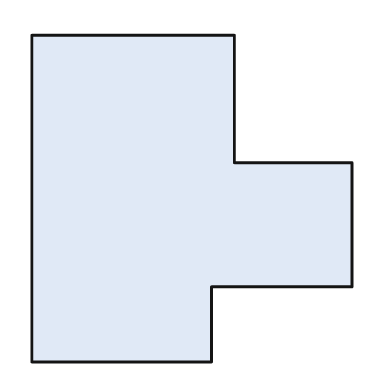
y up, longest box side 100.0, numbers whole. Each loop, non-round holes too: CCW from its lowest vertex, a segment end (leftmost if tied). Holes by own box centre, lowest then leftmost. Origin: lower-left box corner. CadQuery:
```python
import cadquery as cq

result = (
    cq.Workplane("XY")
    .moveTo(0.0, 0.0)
    .lineTo(55.0, 0.0)
    .lineTo(55.0, 23.0)
    .lineTo(98.0, 23.0)
    .lineTo(98.0, 61.0)
    .lineTo(62.0, 61.0)
    .lineTo(62.0, 100.0)
    .lineTo(0.0, 100.0)
    .close()
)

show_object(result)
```